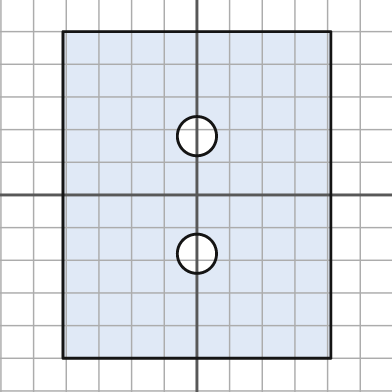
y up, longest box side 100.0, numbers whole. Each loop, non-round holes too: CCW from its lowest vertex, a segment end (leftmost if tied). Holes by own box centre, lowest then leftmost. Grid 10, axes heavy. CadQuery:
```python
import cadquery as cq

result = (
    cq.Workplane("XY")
    .moveTo(-41.0, -50.0)
    .lineTo(41.0, -50.0)
    .lineTo(41.0, 50.0)
    .lineTo(-41.0, 50.0)
    .close()
    .moveTo(0.0, -18.0)
    .circle(6.0)
    .moveTo(0.0, 18.0)
    .circle(6.0)
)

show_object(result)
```